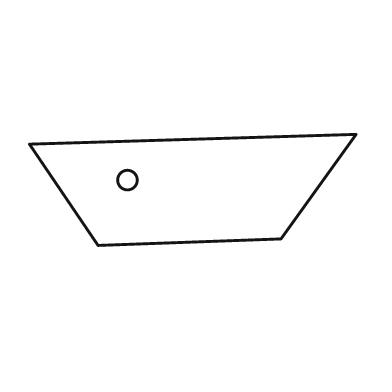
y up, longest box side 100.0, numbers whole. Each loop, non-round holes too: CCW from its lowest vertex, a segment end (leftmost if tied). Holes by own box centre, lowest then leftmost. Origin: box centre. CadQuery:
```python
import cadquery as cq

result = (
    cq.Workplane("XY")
    .moveTo(-29.0, -17.0)
    .lineTo(27.0, -15.0)
    .lineTo(50.0, 17.0)
    .lineTo(-50.0, 14.0)
    .close()
    .moveTo(-20.0, 3.0)
    .circle(3.0)
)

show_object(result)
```